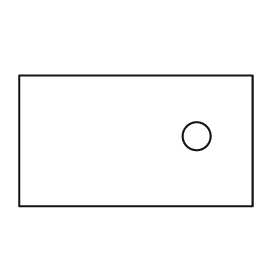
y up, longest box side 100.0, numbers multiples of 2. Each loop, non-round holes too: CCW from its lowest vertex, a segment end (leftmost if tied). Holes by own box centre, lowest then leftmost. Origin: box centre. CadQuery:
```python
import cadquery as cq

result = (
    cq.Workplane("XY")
    .moveTo(-50.0, -28.0)
    .lineTo(50.0, -28.0)
    .lineTo(50.0, 28.0)
    .lineTo(-50.0, 28.0)
    .close()
    .moveTo(26.0, 2.0)
    .circle(6.0)
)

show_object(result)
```